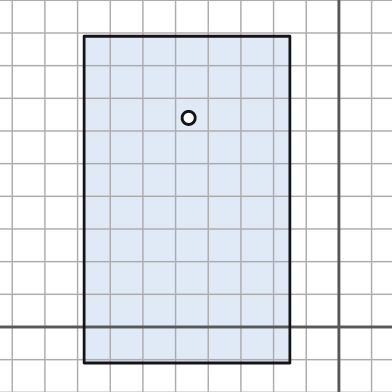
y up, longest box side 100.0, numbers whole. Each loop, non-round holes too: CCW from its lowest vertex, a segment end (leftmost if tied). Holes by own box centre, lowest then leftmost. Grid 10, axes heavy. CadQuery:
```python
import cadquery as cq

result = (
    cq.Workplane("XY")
    .moveTo(-78.0, -11.0)
    .lineTo(-15.0, -11.0)
    .lineTo(-15.0, 89.0)
    .lineTo(-78.0, 89.0)
    .close()
    .moveTo(-46.0, 64.0)
    .circle(2.0)
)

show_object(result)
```